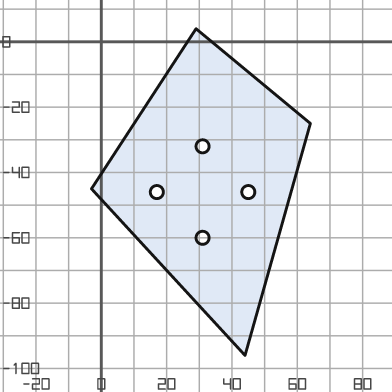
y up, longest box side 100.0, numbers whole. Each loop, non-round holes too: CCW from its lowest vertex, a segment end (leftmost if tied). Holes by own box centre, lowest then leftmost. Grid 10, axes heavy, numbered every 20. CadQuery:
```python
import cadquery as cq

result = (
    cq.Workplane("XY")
    .moveTo(44.0, -96.0)
    .lineTo(64.0, -25.0)
    .lineTo(29.0, 4.0)
    .lineTo(-3.0, -45.0)
    .close()
    .moveTo(31.0, -60.0)
    .circle(2.0)
    .moveTo(17.0, -46.0)
    .circle(2.0)
    .moveTo(45.0, -46.0)
    .circle(2.0)
    .moveTo(31.0, -32.0)
    .circle(2.0)
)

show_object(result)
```